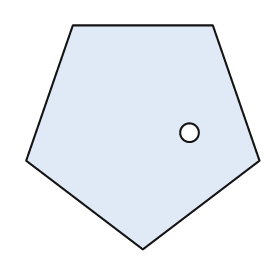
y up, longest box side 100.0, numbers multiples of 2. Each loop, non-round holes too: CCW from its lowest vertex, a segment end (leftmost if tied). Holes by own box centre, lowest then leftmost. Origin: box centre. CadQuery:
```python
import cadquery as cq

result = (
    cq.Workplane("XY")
    .moveTo(0.0, -48.0)
    .lineTo(50.0, -10.0)
    .lineTo(30.0, 48.0)
    .lineTo(-30.0, 48.0)
    .lineTo(-50.0, -10.0)
    .close()
    .moveTo(20.0, 2.0)
    .circle(4.0)
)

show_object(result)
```